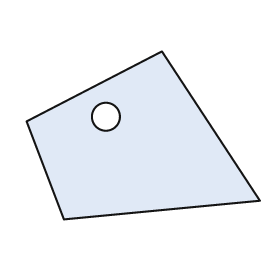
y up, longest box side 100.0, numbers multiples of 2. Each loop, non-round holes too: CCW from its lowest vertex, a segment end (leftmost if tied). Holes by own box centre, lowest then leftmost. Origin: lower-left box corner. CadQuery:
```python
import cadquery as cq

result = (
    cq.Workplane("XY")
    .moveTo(16.0, 0.0)
    .lineTo(100.0, 8.0)
    .lineTo(58.0, 72.0)
    .lineTo(0.0, 42.0)
    .close()
    .moveTo(34.0, 44.0)
    .circle(6.0)
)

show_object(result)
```